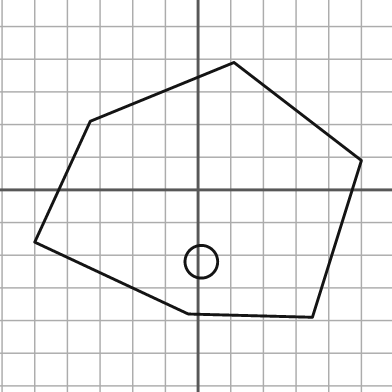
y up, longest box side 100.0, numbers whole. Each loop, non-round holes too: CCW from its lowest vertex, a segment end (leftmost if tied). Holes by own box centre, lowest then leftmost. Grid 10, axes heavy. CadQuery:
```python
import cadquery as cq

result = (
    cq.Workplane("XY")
    .moveTo(35.0, -39.0)
    .lineTo(50.0, 9.0)
    .lineTo(11.0, 39.0)
    .lineTo(-33.0, 21.0)
    .lineTo(-50.0, -16.0)
    .lineTo(-3.0, -38.0)
    .close()
    .moveTo(1.0, -22.0)
    .circle(5.0)
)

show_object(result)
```